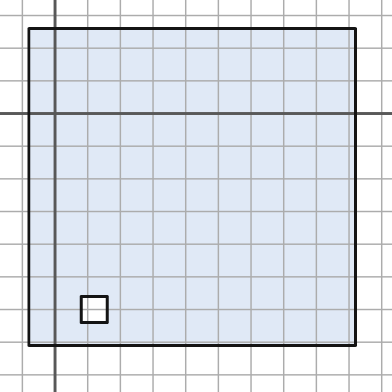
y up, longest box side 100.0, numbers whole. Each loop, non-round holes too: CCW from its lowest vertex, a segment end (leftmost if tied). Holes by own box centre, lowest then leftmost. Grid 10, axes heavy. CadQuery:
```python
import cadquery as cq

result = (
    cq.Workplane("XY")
    .moveTo(-8.0, -71.0)
    .lineTo(92.0, -71.0)
    .lineTo(92.0, 26.0)
    .lineTo(-8.0, 26.0)
    .close()
    .moveTo(8.0, -64.0)
    .lineTo(16.0, -64.0)
    .lineTo(16.0, -56.0)
    .lineTo(8.0, -56.0)
    .close()
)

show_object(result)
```